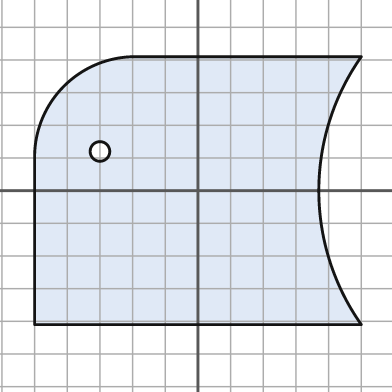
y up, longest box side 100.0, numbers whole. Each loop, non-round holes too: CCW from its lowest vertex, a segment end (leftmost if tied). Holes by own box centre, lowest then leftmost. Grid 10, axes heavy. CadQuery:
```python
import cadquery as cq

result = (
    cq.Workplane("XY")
    .moveTo(-50.0, -41.0)
    .lineTo(50.0, -41.0)
    .threePointArc((37.0, 0.0), (50.0, 41.0))
    .lineTo(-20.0, 41.0)
    .threePointArc((-41.0, 32.0), (-50.0, 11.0))
    .close()
    .moveTo(-30.0, 12.0)
    .circle(3.0)
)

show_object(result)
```